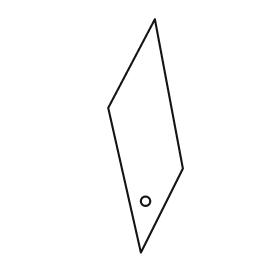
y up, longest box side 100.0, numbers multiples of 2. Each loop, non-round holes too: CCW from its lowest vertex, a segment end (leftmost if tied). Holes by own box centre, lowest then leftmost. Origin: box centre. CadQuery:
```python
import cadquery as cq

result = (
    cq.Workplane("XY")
    .moveTo(-2.0, -50.0)
    .lineTo(16.0, -14.0)
    .lineTo(4.0, 50.0)
    .lineTo(-16.0, 12.0)
    .close()
    .moveTo(0.0, -28.0)
    .circle(2.0)
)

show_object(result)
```